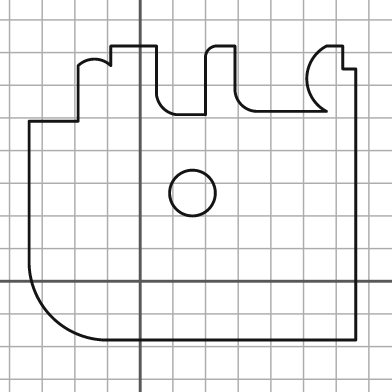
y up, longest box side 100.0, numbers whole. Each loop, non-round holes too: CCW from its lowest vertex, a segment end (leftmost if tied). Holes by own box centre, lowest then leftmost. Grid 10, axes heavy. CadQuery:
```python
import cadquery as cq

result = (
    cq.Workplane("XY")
    .moveTo(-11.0, -18.0)
    .lineTo(66.0, -18.0)
    .lineTo(66.0, 65.0)
    .lineTo(62.0, 65.0)
    .lineTo(62.0, 72.0)
    .lineTo(57.0, 72.0)
    .threePointArc((51.0, 62.0), (57.0, 52.0))
    .lineTo(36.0, 52.0)
    .threePointArc((31.0, 54.0), (29.0, 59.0))
    .lineTo(29.0, 72.0)
    .lineTo(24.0, 72.0)
    .threePointArc((21.0, 71.0), (20.0, 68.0))
    .lineTo(20.0, 51.0)
    .lineTo(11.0, 51.0)
    .threePointArc((7.0, 53.0), (5.0, 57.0))
    .lineTo(5.0, 72.0)
    .lineTo(-9.0, 72.0)
    .lineTo(-9.0, 66.0)
    .threePointArc((-14.0, 68.0), (-19.0, 66.0))
    .lineTo(-19.0, 49.0)
    .lineTo(-34.0, 49.0)
    .lineTo(-34.0, 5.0)
    .threePointArc((-27.0, -11.0), (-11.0, -18.0))
    .close()
    .moveTo(16.0, 27.0)
    .circle(7.0)
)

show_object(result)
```